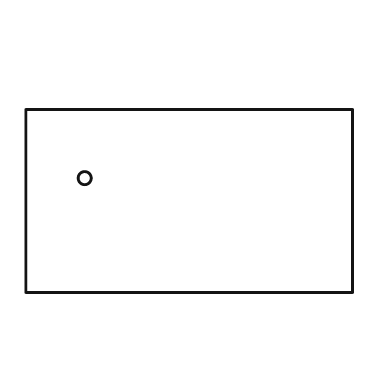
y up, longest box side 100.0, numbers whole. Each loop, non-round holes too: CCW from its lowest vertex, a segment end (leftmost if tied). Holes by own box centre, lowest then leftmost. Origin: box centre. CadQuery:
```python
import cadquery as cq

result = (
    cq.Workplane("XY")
    .moveTo(-50.0, -28.0)
    .lineTo(50.0, -28.0)
    .lineTo(50.0, 28.0)
    .lineTo(-50.0, 28.0)
    .close()
    .moveTo(-32.0, 7.0)
    .circle(2.0)
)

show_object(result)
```